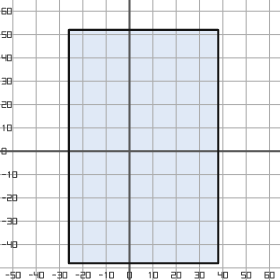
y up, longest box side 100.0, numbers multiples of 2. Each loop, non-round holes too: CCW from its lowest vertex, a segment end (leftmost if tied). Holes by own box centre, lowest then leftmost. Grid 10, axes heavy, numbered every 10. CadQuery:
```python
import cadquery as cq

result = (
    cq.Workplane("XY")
    .moveTo(-26.0, -48.0)
    .lineTo(38.0, -48.0)
    .lineTo(38.0, 52.0)
    .lineTo(-26.0, 52.0)
    .close()
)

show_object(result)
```